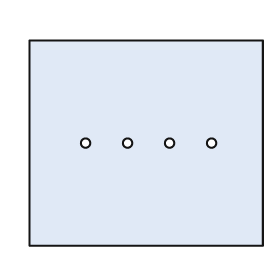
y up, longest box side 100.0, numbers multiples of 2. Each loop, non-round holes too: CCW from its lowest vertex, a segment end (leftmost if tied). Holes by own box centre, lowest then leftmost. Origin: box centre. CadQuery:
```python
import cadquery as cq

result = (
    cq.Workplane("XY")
    .moveTo(-50.0, -44.0)
    .lineTo(50.0, -44.0)
    .lineTo(50.0, 44.0)
    .lineTo(-50.0, 44.0)
    .close()
    .moveTo(-26.0, 0.0)
    .circle(2.0)
    .moveTo(-8.0, 0.0)
    .circle(2.0)
    .moveTo(10.0, 0.0)
    .circle(2.0)
    .moveTo(28.0, 0.0)
    .circle(2.0)
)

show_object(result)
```